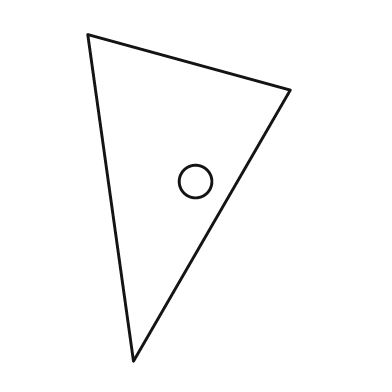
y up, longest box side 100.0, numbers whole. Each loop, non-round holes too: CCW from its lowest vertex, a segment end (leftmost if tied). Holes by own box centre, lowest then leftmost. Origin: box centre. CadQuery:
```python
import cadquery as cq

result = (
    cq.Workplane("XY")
    .moveTo(-17.0, -50.0)
    .lineTo(31.0, 33.0)
    .lineTo(-31.0, 50.0)
    .close()
    .moveTo(2.0, 5.0)
    .circle(5.0)
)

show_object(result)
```